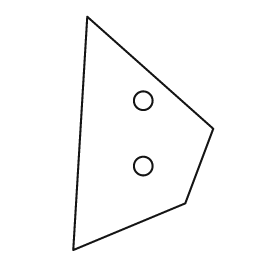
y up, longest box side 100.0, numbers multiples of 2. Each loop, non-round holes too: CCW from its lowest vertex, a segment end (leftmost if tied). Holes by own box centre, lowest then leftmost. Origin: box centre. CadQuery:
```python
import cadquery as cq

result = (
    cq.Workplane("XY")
    .moveTo(-30.0, -50.0)
    .lineTo(18.0, -30.0)
    .lineTo(30.0, 2.0)
    .lineTo(-24.0, 50.0)
    .close()
    .moveTo(0.0, -14.0)
    .circle(4.0)
    .moveTo(0.0, 14.0)
    .circle(4.0)
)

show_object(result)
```